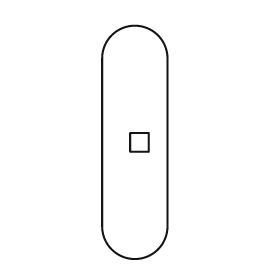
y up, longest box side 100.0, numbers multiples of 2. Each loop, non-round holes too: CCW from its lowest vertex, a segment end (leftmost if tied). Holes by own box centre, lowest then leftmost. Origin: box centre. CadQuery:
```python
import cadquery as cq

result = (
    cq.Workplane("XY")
    .moveTo(-14.0, -36.0)
    .threePointArc((0.0, -50.0), (14.0, -36.0))
    .lineTo(14.0, 36.0)
    .threePointArc((0.0, 50.0), (-14.0, 36.0))
    .close()
    .moveTo(-2.0, -4.0)
    .lineTo(6.0, -4.0)
    .lineTo(6.0, 4.0)
    .lineTo(-2.0, 4.0)
    .close()
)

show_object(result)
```